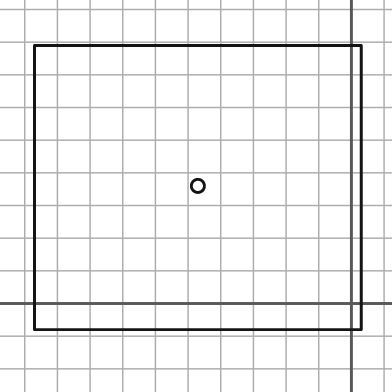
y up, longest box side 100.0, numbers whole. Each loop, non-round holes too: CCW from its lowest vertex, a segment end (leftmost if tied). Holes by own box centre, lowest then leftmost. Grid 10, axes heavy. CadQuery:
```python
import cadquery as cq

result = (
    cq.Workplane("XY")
    .moveTo(-97.0, -8.0)
    .lineTo(3.0, -8.0)
    .lineTo(3.0, 79.0)
    .lineTo(-97.0, 79.0)
    .close()
    .moveTo(-47.0, 36.0)
    .circle(2.0)
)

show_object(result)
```